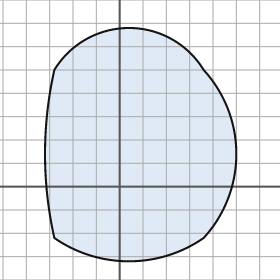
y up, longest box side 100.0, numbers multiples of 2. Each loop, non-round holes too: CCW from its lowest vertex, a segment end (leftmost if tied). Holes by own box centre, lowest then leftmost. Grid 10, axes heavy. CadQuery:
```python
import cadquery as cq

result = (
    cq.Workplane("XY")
    .moveTo(-28.0, -22.0)
    .threePointArc((4.0, -32.0), (36.0, -22.0))
    .threePointArc((50.0, 14.0), (36.0, 50.0))
    .threePointArc((4.0, 68.0), (-28.0, 50.0))
    .threePointArc((-32.0, 14.0), (-28.0, -22.0))
    .close()
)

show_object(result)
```